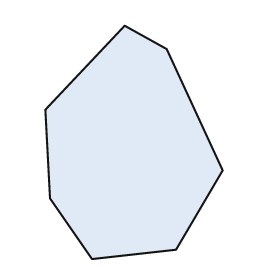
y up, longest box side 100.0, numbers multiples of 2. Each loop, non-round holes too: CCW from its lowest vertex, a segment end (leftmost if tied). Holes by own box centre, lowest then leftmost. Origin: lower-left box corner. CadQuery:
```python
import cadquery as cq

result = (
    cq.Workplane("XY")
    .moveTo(20.0, 0.0)
    .lineTo(56.0, 4.0)
    .lineTo(76.0, 38.0)
    .lineTo(52.0, 90.0)
    .lineTo(34.0, 100.0)
    .lineTo(0.0, 64.0)
    .lineTo(2.0, 26.0)
    .close()
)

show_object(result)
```